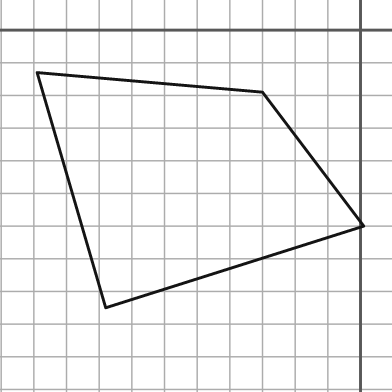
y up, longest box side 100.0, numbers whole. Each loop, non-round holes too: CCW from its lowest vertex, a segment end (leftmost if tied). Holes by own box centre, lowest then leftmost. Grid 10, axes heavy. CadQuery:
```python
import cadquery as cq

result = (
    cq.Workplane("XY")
    .moveTo(-78.0, -85.0)
    .lineTo(1.0, -60.0)
    .lineTo(-30.0, -19.0)
    .lineTo(-99.0, -13.0)
    .close()
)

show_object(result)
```